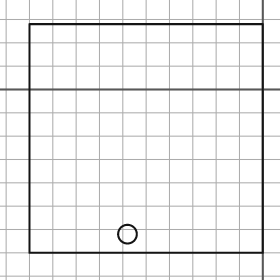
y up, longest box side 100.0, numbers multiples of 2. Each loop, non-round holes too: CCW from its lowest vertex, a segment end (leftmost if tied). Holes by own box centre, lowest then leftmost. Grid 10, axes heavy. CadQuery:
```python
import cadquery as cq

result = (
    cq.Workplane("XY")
    .moveTo(-100.0, -70.0)
    .lineTo(0.0, -70.0)
    .lineTo(0.0, 28.0)
    .lineTo(-100.0, 28.0)
    .close()
    .moveTo(-58.0, -62.0)
    .circle(4.0)
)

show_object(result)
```